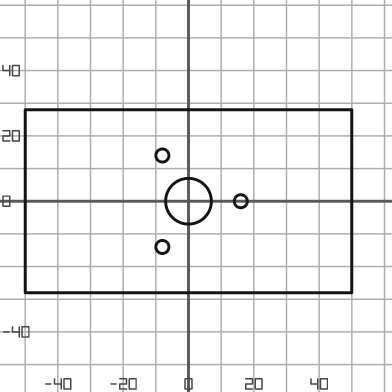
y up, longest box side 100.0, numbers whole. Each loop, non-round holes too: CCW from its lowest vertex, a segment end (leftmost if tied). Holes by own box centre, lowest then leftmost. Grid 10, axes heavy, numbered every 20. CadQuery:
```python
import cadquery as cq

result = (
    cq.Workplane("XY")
    .moveTo(-50.0, -28.0)
    .lineTo(50.0, -28.0)
    .lineTo(50.0, 28.0)
    .lineTo(-50.0, 28.0)
    .close()
    .moveTo(-8.0, -14.0)
    .circle(2.0)
    .moveTo(0.0, 0.0)
    .circle(7.0)
    .moveTo(16.0, 0.0)
    .circle(2.0)
    .moveTo(-8.0, 14.0)
    .circle(2.0)
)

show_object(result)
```